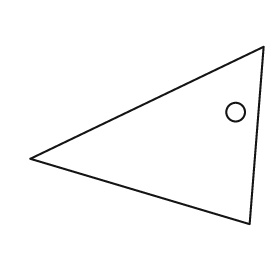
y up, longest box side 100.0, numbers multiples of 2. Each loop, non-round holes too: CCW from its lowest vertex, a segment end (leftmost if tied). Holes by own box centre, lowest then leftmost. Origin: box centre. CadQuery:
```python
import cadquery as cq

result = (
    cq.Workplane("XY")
    .moveTo(44.0, -38.0)
    .lineTo(50.0, 38.0)
    .lineTo(-50.0, -10.0)
    .close()
    .moveTo(38.0, 10.0)
    .circle(4.0)
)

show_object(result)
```